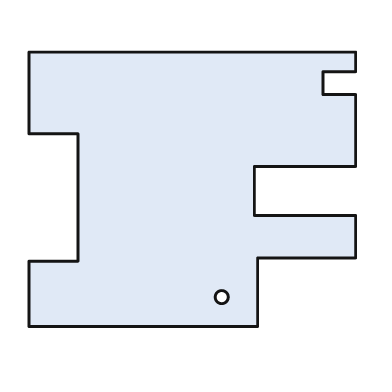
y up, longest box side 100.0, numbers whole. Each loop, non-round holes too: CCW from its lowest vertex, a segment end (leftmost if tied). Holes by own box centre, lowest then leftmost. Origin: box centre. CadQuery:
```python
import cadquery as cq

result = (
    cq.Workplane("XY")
    .moveTo(-50.0, -42.0)
    .lineTo(20.0, -42.0)
    .lineTo(20.0, -21.0)
    .lineTo(50.0, -21.0)
    .lineTo(50.0, -8.0)
    .lineTo(19.0, -8.0)
    .lineTo(19.0, 7.0)
    .lineTo(50.0, 7.0)
    .lineTo(50.0, 29.0)
    .lineTo(40.0, 29.0)
    .lineTo(40.0, 36.0)
    .lineTo(50.0, 36.0)
    .lineTo(50.0, 42.0)
    .lineTo(-50.0, 42.0)
    .lineTo(-50.0, 17.0)
    .lineTo(-35.0, 17.0)
    .lineTo(-35.0, -22.0)
    .lineTo(-50.0, -22.0)
    .close()
    .moveTo(9.0, -33.0)
    .circle(2.0)
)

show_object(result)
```